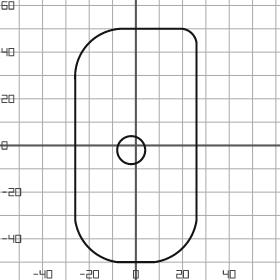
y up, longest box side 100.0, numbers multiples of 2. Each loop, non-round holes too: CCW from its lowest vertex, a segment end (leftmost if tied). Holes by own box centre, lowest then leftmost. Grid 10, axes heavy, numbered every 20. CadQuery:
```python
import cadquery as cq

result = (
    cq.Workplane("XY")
    .moveTo(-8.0, -50.0)
    .lineTo(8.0, -50.0)
    .threePointArc((20.0, -44.0), (26.0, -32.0))
    .lineTo(26.0, 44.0)
    .threePointArc((24.0, 48.0), (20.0, 50.0))
    .lineTo(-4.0, 50.0)
    .threePointArc((-20.0, 44.0), (-26.0, 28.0))
    .lineTo(-26.0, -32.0)
    .threePointArc((-20.0, -44.0), (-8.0, -50.0))
    .close()
    .moveTo(-2.0, -2.0)
    .circle(6.0)
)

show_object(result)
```